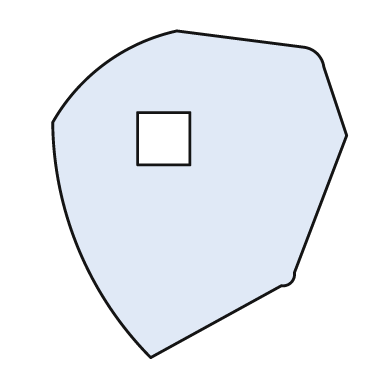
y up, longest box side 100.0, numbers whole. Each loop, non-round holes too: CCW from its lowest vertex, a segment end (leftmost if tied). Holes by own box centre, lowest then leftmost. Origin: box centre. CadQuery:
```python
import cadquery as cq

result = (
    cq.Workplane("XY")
    .moveTo(-15.0, -50.0)
    .lineTo(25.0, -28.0)
    .threePointArc((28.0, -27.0), (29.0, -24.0))
    .lineTo(45.0, 18.0)
    .lineTo(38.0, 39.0)
    .threePointArc((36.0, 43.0), (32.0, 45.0))
    .lineTo(-7.0, 50.0)
    .threePointArc((-29.0, 40.0), (-45.0, 22.0))
    .threePointArc((-37.0, -17.0), (-15.0, -50.0))
    .close()
    .moveTo(-19.0, 9.0)
    .lineTo(-3.0, 9.0)
    .lineTo(-3.0, 25.0)
    .lineTo(-19.0, 25.0)
    .close()
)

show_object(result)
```